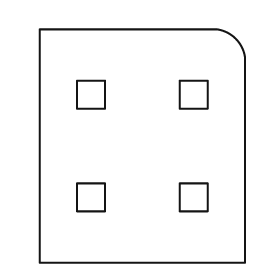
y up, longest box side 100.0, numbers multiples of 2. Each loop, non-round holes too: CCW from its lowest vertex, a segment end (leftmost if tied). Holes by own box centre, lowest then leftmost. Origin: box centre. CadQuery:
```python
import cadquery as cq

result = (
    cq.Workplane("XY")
    .moveTo(-44.0, -50.0)
    .lineTo(44.0, -50.0)
    .lineTo(44.0, 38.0)
    .threePointArc((40.0, 46.0), (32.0, 50.0))
    .lineTo(-44.0, 50.0)
    .close()
    .moveTo(-28.0, -28.0)
    .lineTo(-16.0, -28.0)
    .lineTo(-16.0, -16.0)
    .lineTo(-28.0, -16.0)
    .close()
    .moveTo(16.0, -28.0)
    .lineTo(28.0, -28.0)
    .lineTo(28.0, -16.0)
    .lineTo(16.0, -16.0)
    .close()
    .moveTo(-28.0, 16.0)
    .lineTo(-16.0, 16.0)
    .lineTo(-16.0, 28.0)
    .lineTo(-28.0, 28.0)
    .close()
    .moveTo(16.0, 16.0)
    .lineTo(28.0, 16.0)
    .lineTo(28.0, 28.0)
    .lineTo(16.0, 28.0)
    .close()
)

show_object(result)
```